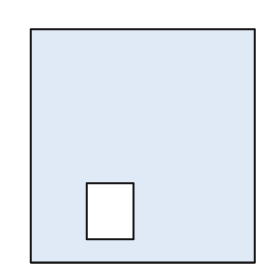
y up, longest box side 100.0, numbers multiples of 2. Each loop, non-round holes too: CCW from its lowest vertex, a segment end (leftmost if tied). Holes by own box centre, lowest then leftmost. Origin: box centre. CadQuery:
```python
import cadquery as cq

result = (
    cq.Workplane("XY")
    .moveTo(-48.0, -50.0)
    .lineTo(48.0, -50.0)
    .lineTo(48.0, 50.0)
    .lineTo(-48.0, 50.0)
    .close()
    .moveTo(-24.0, -40.0)
    .lineTo(-4.0, -40.0)
    .lineTo(-4.0, -16.0)
    .lineTo(-24.0, -16.0)
    .close()
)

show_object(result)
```